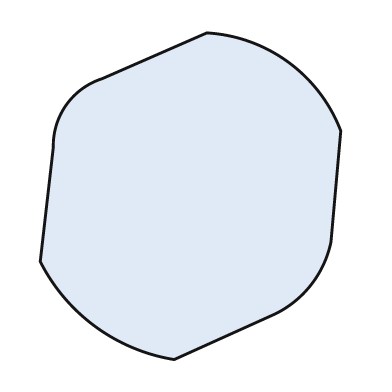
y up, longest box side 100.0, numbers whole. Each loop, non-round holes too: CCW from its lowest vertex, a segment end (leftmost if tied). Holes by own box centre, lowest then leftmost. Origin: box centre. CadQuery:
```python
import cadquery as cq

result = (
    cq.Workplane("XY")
    .moveTo(-5.0, -50.0)
    .lineTo(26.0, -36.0)
    .threePointArc((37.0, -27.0), (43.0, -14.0))
    .lineTo(46.0, 20.0)
    .threePointArc((30.0, 41.0), (5.0, 50.0))
    .lineTo(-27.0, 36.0)
    .threePointArc((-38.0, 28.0), (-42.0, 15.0))
    .lineTo(-46.0, -20.0)
    .threePointArc((-29.0, -40.0), (-5.0, -50.0))
    .close()
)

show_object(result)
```